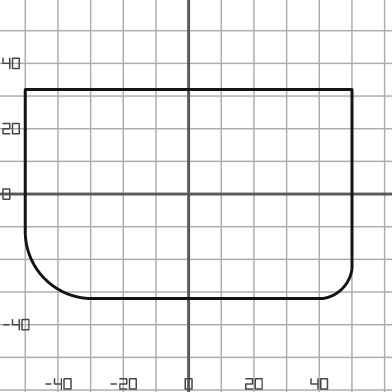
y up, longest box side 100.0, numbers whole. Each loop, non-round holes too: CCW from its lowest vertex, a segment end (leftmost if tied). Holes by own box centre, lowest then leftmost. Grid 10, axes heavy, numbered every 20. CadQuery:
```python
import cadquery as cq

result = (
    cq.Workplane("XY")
    .moveTo(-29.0, -32.0)
    .lineTo(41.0, -32.0)
    .threePointArc((47.0, -29.0), (50.0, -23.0))
    .lineTo(50.0, 32.0)
    .lineTo(-50.0, 32.0)
    .lineTo(-50.0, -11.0)
    .threePointArc((-44.0, -26.0), (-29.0, -32.0))
    .close()
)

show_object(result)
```